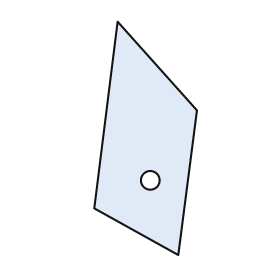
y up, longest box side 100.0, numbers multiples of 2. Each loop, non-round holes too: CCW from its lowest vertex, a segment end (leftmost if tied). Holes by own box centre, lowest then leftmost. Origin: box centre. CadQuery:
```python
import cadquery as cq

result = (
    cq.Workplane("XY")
    .moveTo(14.0, -50.0)
    .lineTo(22.0, 12.0)
    .lineTo(-12.0, 50.0)
    .lineTo(-22.0, -30.0)
    .close()
    .moveTo(2.0, -18.0)
    .circle(4.0)
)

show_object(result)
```